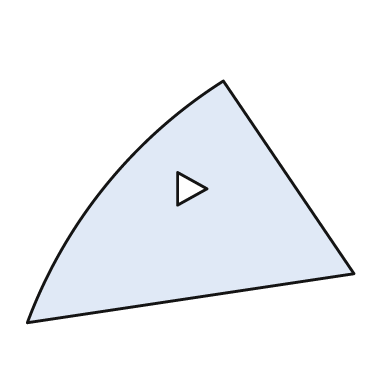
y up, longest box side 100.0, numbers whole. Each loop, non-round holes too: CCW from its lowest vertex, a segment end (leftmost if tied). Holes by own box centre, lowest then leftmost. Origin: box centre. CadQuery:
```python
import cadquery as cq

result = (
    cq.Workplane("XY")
    .moveTo(-50.0, -37.0)
    .lineTo(50.0, -22.0)
    .lineTo(10.0, 37.0)
    .threePointArc((-26.0, 5.0), (-50.0, -37.0))
    .close()
    .moveTo(-4.0, -1.0)
    .lineTo(5.0, 4.0)
    .lineTo(-4.0, 9.0)
    .close()
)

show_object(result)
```